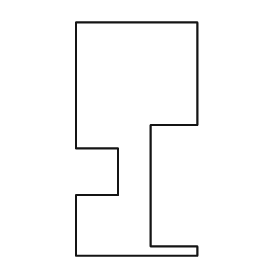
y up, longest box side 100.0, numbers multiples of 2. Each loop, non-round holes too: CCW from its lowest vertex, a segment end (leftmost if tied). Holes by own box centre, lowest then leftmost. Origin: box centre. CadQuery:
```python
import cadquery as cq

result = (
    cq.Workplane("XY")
    .moveTo(-26.0, -50.0)
    .lineTo(26.0, -50.0)
    .lineTo(26.0, -46.0)
    .lineTo(6.0, -46.0)
    .lineTo(6.0, 6.0)
    .lineTo(26.0, 6.0)
    .lineTo(26.0, 50.0)
    .lineTo(-26.0, 50.0)
    .lineTo(-26.0, -4.0)
    .lineTo(-8.0, -4.0)
    .lineTo(-8.0, -24.0)
    .lineTo(-26.0, -24.0)
    .close()
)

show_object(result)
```